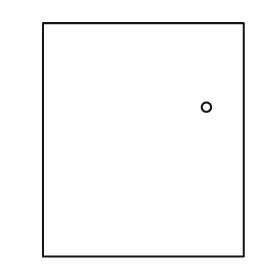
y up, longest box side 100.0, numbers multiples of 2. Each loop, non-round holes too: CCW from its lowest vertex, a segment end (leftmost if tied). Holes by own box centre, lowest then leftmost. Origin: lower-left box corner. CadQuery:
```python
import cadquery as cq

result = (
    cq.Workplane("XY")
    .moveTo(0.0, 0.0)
    .lineTo(86.0, 0.0)
    .lineTo(86.0, 100.0)
    .lineTo(0.0, 100.0)
    .close()
    .moveTo(70.0, 64.0)
    .circle(2.0)
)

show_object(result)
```